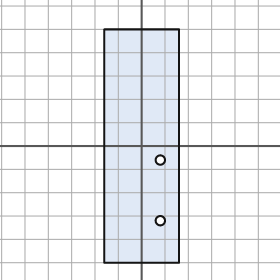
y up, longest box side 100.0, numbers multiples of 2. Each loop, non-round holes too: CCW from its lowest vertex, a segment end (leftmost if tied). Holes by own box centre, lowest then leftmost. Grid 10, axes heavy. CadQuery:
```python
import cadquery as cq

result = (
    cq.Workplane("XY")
    .moveTo(-16.0, -50.0)
    .lineTo(16.0, -50.0)
    .lineTo(16.0, 50.0)
    .lineTo(-16.0, 50.0)
    .close()
    .moveTo(8.0, -32.0)
    .circle(2.0)
    .moveTo(8.0, -6.0)
    .circle(2.0)
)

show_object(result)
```